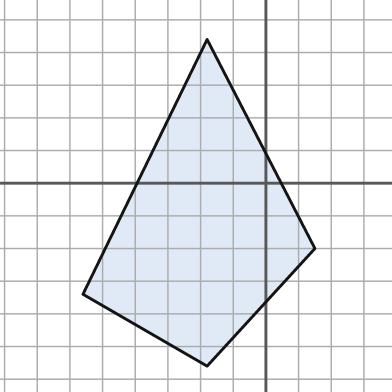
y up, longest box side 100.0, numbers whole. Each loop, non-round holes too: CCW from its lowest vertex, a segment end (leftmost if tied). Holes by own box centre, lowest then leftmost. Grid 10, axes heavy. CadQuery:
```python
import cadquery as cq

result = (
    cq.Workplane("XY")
    .moveTo(-18.0, -56.0)
    .lineTo(15.0, -20.0)
    .lineTo(-18.0, 44.0)
    .lineTo(-56.0, -34.0)
    .close()
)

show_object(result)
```